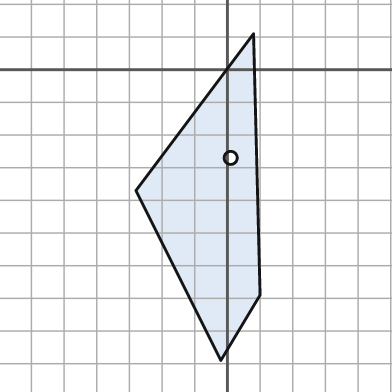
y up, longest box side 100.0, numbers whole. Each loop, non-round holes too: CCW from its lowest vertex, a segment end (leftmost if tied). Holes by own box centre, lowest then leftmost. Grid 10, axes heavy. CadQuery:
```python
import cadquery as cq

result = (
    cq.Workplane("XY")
    .moveTo(-2.0, -89.0)
    .lineTo(10.0, -69.0)
    .lineTo(8.0, 11.0)
    .lineTo(-28.0, -37.0)
    .close()
    .moveTo(1.0, -27.0)
    .circle(2.0)
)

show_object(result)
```